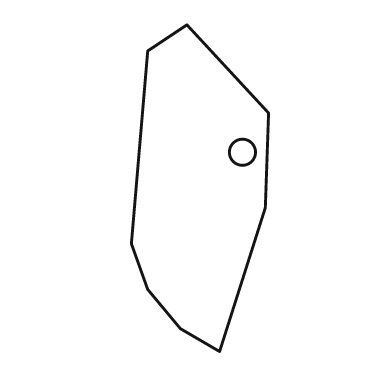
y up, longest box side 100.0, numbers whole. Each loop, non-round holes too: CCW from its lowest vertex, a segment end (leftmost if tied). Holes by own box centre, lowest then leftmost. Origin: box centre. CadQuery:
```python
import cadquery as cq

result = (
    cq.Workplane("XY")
    .moveTo(6.0, -50.0)
    .lineTo(20.0, -6.0)
    .lineTo(21.0, 23.0)
    .lineTo(-4.0, 50.0)
    .lineTo(-16.0, 42.0)
    .lineTo(-21.0, -17.0)
    .lineTo(-16.0, -31.0)
    .lineTo(-6.0, -43.0)
    .close()
    .moveTo(13.0, 11.0)
    .circle(4.0)
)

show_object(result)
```